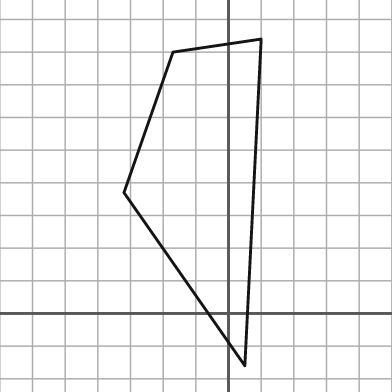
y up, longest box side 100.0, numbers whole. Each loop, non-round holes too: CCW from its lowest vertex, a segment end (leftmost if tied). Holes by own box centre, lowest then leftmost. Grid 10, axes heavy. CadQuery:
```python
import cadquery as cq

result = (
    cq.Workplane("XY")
    .moveTo(5.0, -16.0)
    .lineTo(10.0, 84.0)
    .lineTo(-17.0, 80.0)
    .lineTo(-32.0, 37.0)
    .close()
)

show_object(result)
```